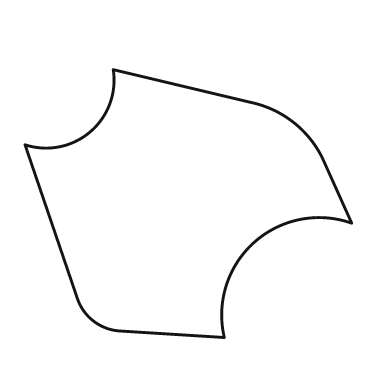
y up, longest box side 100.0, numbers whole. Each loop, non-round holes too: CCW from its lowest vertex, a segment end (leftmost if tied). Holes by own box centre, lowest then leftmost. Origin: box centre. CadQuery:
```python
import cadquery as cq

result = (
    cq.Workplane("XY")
    .moveTo(11.0, -41.0)
    .threePointArc((20.0, -12.0), (50.0, -6.0))
    .lineTo(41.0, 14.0)
    .threePointArc((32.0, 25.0), (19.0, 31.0))
    .lineTo(-23.0, 41.0)
    .threePointArc((-30.0, 22.0), (-50.0, 18.0))
    .lineTo(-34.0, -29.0)
    .threePointArc((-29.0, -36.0), (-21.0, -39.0))
    .close()
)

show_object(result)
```